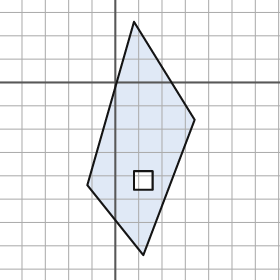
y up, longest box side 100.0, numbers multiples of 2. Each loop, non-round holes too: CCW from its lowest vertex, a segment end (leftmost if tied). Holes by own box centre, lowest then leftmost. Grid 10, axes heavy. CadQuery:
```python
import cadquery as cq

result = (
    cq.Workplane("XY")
    .moveTo(12.0, -74.0)
    .lineTo(34.0, -16.0)
    .lineTo(8.0, 26.0)
    .lineTo(-12.0, -44.0)
    .close()
    .moveTo(8.0, -46.0)
    .lineTo(16.0, -46.0)
    .lineTo(16.0, -38.0)
    .lineTo(8.0, -38.0)
    .close()
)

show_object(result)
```